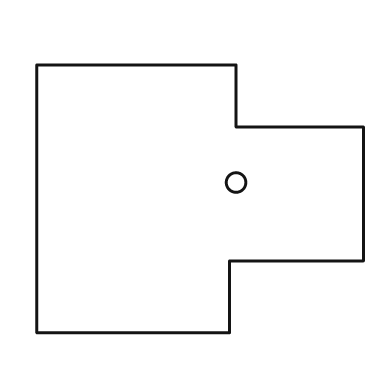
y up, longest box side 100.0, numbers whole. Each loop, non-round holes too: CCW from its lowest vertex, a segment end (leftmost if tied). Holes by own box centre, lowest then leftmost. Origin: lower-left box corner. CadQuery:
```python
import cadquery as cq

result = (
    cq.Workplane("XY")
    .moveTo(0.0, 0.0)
    .lineTo(59.0, 0.0)
    .lineTo(59.0, 22.0)
    .lineTo(100.0, 22.0)
    .lineTo(100.0, 63.0)
    .lineTo(61.0, 63.0)
    .lineTo(61.0, 82.0)
    .lineTo(0.0, 82.0)
    .close()
    .moveTo(61.0, 46.0)
    .circle(3.0)
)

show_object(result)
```